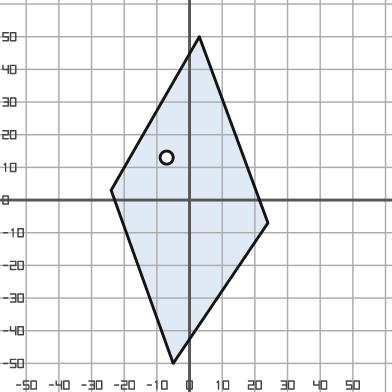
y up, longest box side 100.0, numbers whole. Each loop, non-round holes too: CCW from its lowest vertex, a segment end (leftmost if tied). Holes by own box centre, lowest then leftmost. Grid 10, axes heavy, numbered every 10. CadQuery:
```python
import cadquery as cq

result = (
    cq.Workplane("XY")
    .moveTo(-5.0, -50.0)
    .lineTo(24.0, -7.0)
    .lineTo(3.0, 50.0)
    .lineTo(-24.0, 3.0)
    .close()
    .moveTo(-7.0, 13.0)
    .circle(2.0)
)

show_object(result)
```